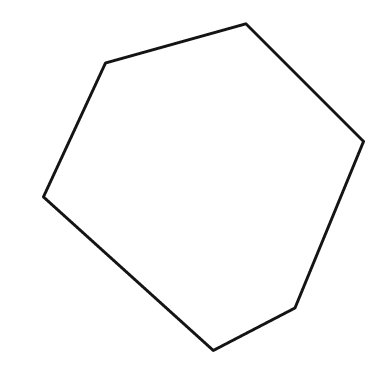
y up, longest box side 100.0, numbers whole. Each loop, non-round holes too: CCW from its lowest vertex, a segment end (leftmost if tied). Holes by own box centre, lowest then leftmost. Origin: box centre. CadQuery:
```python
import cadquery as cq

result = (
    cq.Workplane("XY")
    .moveTo(3.0, -50.0)
    .lineTo(28.0, -37.0)
    .lineTo(49.0, 14.0)
    .lineTo(13.0, 50.0)
    .lineTo(-30.0, 38.0)
    .lineTo(-49.0, -3.0)
    .close()
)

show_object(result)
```